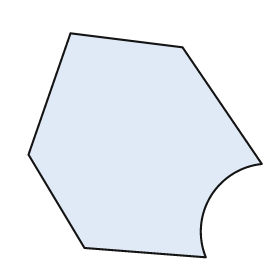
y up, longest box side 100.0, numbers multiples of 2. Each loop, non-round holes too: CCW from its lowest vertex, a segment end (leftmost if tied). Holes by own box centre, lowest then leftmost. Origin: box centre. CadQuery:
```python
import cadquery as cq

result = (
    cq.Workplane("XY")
    .moveTo(26.0, -48.0)
    .threePointArc((28.0, -22.0), (50.0, -8.0))
    .lineTo(16.0, 42.0)
    .lineTo(-32.0, 48.0)
    .lineTo(-50.0, -4.0)
    .lineTo(-26.0, -44.0)
    .close()
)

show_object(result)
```